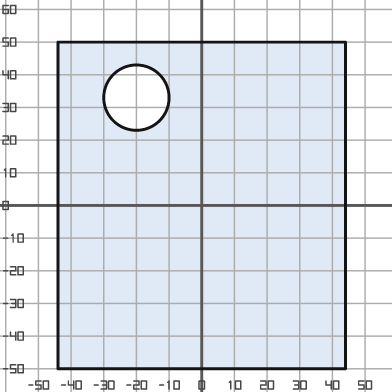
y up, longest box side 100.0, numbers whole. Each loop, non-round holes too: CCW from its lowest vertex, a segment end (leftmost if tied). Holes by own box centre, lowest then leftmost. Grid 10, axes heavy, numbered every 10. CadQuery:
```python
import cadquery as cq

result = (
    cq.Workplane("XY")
    .moveTo(-44.0, -50.0)
    .lineTo(44.0, -50.0)
    .lineTo(44.0, 50.0)
    .lineTo(-44.0, 50.0)
    .close()
    .moveTo(-20.0, 33.0)
    .circle(10.0)
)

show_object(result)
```